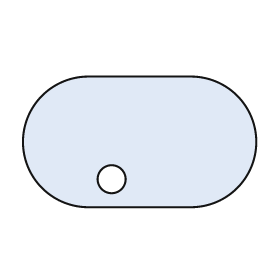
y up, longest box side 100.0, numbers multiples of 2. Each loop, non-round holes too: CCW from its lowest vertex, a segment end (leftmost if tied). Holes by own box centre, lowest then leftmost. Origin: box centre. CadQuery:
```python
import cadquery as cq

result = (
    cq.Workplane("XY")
    .moveTo(-22.0, -28.0)
    .lineTo(22.0, -28.0)
    .threePointArc((50.0, 0.0), (22.0, 28.0))
    .lineTo(-22.0, 28.0)
    .threePointArc((-50.0, 0.0), (-22.0, -28.0))
    .close()
    .moveTo(-12.0, -16.0)
    .circle(6.0)
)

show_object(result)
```